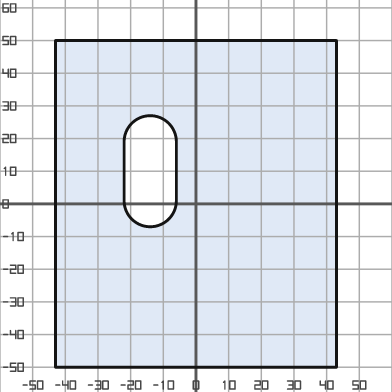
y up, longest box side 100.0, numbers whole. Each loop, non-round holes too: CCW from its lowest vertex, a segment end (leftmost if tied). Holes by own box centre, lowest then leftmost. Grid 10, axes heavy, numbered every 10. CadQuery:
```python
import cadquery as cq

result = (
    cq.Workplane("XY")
    .moveTo(-43.0, -50.0)
    .lineTo(43.0, -50.0)
    .lineTo(43.0, 50.0)
    .lineTo(-43.0, 50.0)
    .close()
    .moveTo(-22.0, 1.0)
    .threePointArc((-14.0, -7.0), (-6.0, 1.0))
    .lineTo(-6.0, 19.0)
    .threePointArc((-14.0, 27.0), (-22.0, 19.0))
    .close()
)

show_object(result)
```